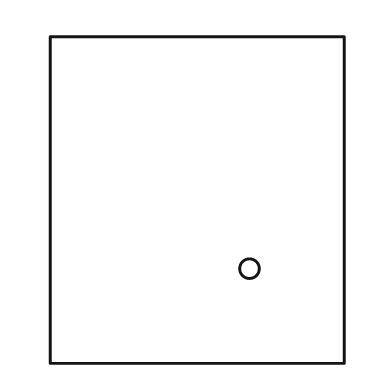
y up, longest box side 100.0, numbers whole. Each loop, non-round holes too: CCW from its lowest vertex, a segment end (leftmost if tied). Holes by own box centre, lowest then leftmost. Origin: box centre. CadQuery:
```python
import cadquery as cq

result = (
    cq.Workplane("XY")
    .moveTo(-45.0, -50.0)
    .lineTo(45.0, -50.0)
    .lineTo(45.0, 50.0)
    .lineTo(-45.0, 50.0)
    .close()
    .moveTo(16.0, -21.0)
    .circle(3.0)
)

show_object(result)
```